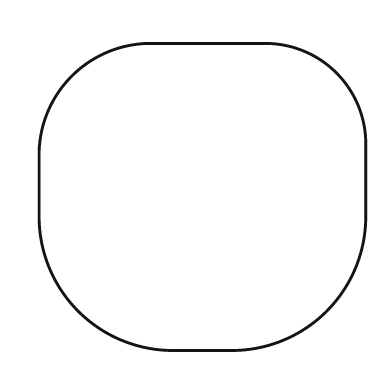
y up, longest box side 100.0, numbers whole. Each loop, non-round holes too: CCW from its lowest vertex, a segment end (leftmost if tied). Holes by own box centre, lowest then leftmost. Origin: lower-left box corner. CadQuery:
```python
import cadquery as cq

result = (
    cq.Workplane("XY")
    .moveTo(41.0, 0.0)
    .lineTo(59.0, 0.0)
    .threePointArc((88.0, 12.0), (100.0, 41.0))
    .lineTo(100.0, 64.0)
    .threePointArc((91.0, 85.0), (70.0, 94.0))
    .lineTo(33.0, 94.0)
    .threePointArc((10.0, 84.0), (0.0, 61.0))
    .lineTo(0.0, 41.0)
    .threePointArc((12.0, 12.0), (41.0, 0.0))
    .close()
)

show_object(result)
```